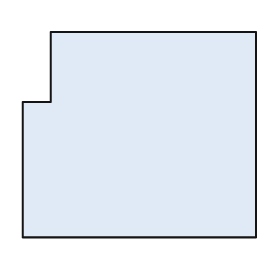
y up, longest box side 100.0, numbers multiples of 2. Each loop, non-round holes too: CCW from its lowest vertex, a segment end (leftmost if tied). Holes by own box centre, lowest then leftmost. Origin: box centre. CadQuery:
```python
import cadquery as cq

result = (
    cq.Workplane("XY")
    .moveTo(-50.0, -44.0)
    .lineTo(50.0, -44.0)
    .lineTo(50.0, 44.0)
    .lineTo(-38.0, 44.0)
    .lineTo(-38.0, 14.0)
    .lineTo(-50.0, 14.0)
    .close()
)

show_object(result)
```